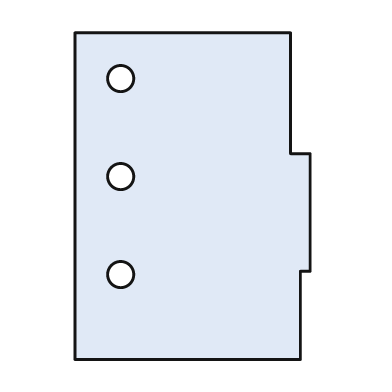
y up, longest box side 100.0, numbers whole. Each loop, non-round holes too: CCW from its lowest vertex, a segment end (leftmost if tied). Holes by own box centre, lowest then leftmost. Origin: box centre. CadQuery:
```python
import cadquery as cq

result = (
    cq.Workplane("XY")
    .moveTo(-36.0, -50.0)
    .lineTo(33.0, -50.0)
    .lineTo(33.0, -23.0)
    .lineTo(36.0, -23.0)
    .lineTo(36.0, 13.0)
    .lineTo(30.0, 13.0)
    .lineTo(30.0, 50.0)
    .lineTo(-36.0, 50.0)
    .close()
    .moveTo(-22.0, -24.0)
    .circle(4.0)
    .moveTo(-22.0, 6.0)
    .circle(4.0)
    .moveTo(-22.0, 36.0)
    .circle(4.0)
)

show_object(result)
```